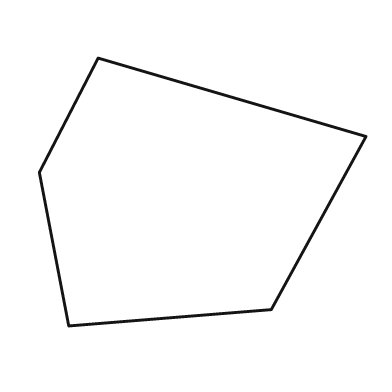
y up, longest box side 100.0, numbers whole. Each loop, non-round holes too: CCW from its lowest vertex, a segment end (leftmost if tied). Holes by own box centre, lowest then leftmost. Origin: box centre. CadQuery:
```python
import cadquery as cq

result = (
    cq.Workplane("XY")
    .moveTo(-41.0, -41.0)
    .lineTo(21.0, -36.0)
    .lineTo(50.0, 17.0)
    .lineTo(-32.0, 41.0)
    .lineTo(-50.0, 6.0)
    .close()
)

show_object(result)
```